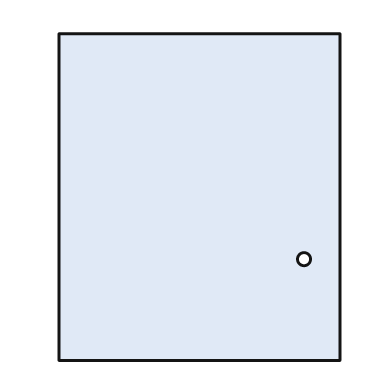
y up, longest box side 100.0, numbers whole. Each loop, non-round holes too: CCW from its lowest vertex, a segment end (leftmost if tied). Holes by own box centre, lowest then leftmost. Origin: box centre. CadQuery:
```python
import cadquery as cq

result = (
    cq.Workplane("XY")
    .moveTo(-43.0, -50.0)
    .lineTo(43.0, -50.0)
    .lineTo(43.0, 50.0)
    .lineTo(-43.0, 50.0)
    .close()
    .moveTo(32.0, -19.0)
    .circle(2.0)
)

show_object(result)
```